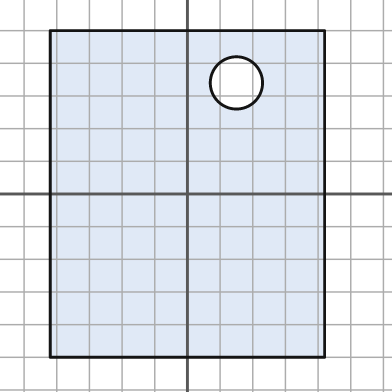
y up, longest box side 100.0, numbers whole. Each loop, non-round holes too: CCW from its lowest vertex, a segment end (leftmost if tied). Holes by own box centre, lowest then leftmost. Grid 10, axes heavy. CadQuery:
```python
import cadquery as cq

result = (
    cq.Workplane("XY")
    .moveTo(-42.0, -50.0)
    .lineTo(42.0, -50.0)
    .lineTo(42.0, 50.0)
    .lineTo(-42.0, 50.0)
    .close()
    .moveTo(15.0, 34.0)
    .circle(8.0)
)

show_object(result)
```